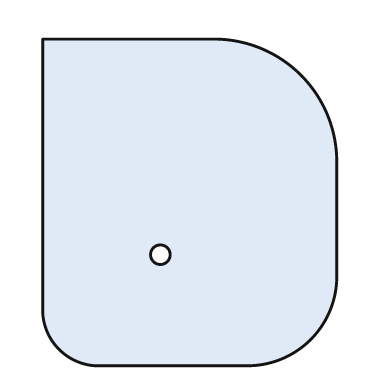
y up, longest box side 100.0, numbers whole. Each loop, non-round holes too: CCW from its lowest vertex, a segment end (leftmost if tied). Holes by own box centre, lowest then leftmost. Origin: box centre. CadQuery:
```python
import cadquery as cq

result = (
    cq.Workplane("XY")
    .moveTo(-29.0, -50.0)
    .lineTo(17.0, -50.0)
    .threePointArc((37.0, -42.0), (45.0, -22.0))
    .lineTo(45.0, 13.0)
    .threePointArc((34.0, 39.0), (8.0, 50.0))
    .lineTo(-45.0, 50.0)
    .lineTo(-45.0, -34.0)
    .threePointArc((-40.0, -45.0), (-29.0, -50.0))
    .close()
    .moveTo(-9.0, -16.0)
    .circle(3.0)
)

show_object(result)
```